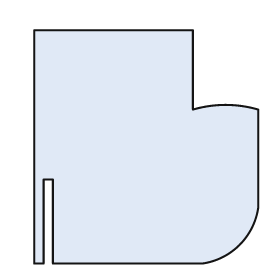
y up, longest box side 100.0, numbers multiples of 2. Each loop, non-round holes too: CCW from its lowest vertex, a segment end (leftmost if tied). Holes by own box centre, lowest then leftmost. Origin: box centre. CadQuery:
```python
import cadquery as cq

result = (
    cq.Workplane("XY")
    .moveTo(-48.0, -50.0)
    .lineTo(-44.0, -50.0)
    .lineTo(-44.0, -14.0)
    .lineTo(-40.0, -14.0)
    .lineTo(-40.0, -50.0)
    .lineTo(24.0, -50.0)
    .threePointArc((40.0, -42.0), (48.0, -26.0))
    .lineTo(48.0, 16.0)
    .threePointArc((34.0, 18.0), (20.0, 16.0))
    .lineTo(20.0, 50.0)
    .lineTo(-48.0, 50.0)
    .close()
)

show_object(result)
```